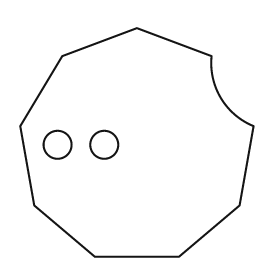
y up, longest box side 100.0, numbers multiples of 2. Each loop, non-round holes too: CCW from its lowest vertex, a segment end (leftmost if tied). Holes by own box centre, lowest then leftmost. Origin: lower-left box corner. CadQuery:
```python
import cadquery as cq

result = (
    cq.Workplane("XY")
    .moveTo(32.0, 0.0)
    .lineTo(68.0, 0.0)
    .lineTo(94.0, 22.0)
    .lineTo(100.0, 56.0)
    .threePointArc((86.0, 68.0), (82.0, 86.0))
    .lineTo(50.0, 98.0)
    .lineTo(18.0, 86.0)
    .lineTo(0.0, 56.0)
    .lineTo(6.0, 22.0)
    .close()
    .moveTo(16.0, 48.0)
    .circle(6.0)
    .moveTo(36.0, 48.0)
    .circle(6.0)
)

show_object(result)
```